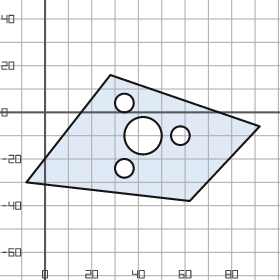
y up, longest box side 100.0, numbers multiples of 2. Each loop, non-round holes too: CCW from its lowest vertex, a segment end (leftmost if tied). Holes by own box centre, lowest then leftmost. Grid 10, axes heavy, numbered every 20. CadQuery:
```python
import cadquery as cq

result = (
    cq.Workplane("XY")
    .moveTo(62.0, -38.0)
    .lineTo(92.0, -6.0)
    .lineTo(28.0, 16.0)
    .lineTo(-8.0, -30.0)
    .close()
    .moveTo(34.0, -24.0)
    .circle(4.0)
    .moveTo(42.0, -10.0)
    .circle(8.0)
    .moveTo(58.0, -10.0)
    .circle(4.0)
    .moveTo(34.0, 4.0)
    .circle(4.0)
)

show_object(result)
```